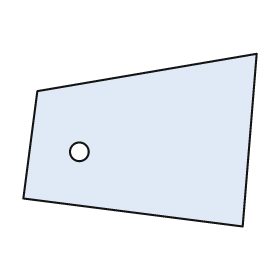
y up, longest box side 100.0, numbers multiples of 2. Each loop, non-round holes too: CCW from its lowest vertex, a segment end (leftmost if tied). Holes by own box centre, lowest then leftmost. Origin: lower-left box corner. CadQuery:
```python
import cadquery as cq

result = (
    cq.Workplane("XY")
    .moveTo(94.0, 0.0)
    .lineTo(100.0, 74.0)
    .lineTo(6.0, 58.0)
    .lineTo(0.0, 12.0)
    .close()
    .moveTo(24.0, 32.0)
    .circle(4.0)
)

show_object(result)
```